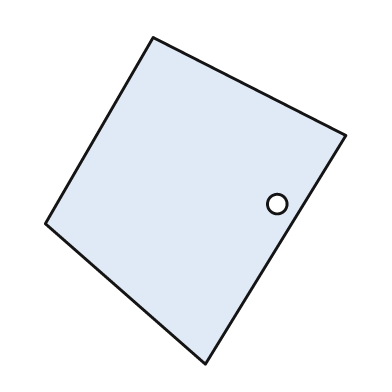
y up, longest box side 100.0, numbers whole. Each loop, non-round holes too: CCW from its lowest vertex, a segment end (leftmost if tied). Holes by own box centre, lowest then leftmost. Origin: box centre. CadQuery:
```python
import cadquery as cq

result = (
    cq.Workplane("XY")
    .moveTo(3.0, -50.0)
    .lineTo(46.0, 20.0)
    .lineTo(-13.0, 50.0)
    .lineTo(-46.0, -7.0)
    .close()
    .moveTo(25.0, -1.0)
    .circle(3.0)
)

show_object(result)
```